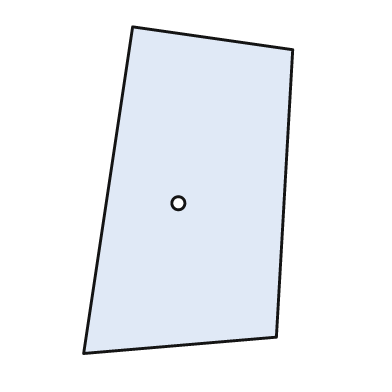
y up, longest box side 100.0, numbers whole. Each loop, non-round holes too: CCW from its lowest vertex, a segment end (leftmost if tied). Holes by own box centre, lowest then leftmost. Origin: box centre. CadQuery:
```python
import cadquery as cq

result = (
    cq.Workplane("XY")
    .moveTo(-32.0, -50.0)
    .lineTo(27.0, -45.0)
    .lineTo(32.0, 43.0)
    .lineTo(-17.0, 50.0)
    .close()
    .moveTo(-3.0, -4.0)
    .circle(2.0)
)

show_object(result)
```